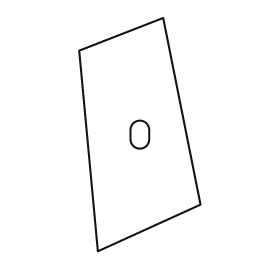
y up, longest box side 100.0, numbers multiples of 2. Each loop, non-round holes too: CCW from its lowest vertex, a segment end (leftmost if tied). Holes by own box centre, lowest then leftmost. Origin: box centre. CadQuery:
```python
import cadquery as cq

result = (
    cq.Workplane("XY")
    .moveTo(-18.0, -50.0)
    .lineTo(26.0, -30.0)
    .lineTo(10.0, 50.0)
    .lineTo(-26.0, 36.0)
    .close()
    .moveTo(-4.0, -2.0)
    .threePointArc((0.0, -6.0), (4.0, -2.0))
    .lineTo(4.0, 2.0)
    .threePointArc((0.0, 6.0), (-4.0, 2.0))
    .close()
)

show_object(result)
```